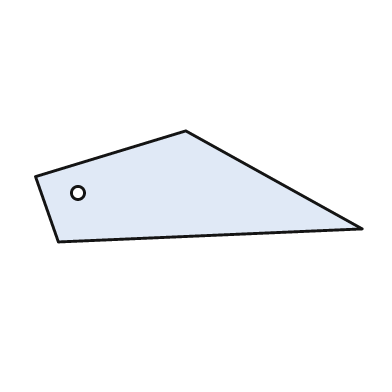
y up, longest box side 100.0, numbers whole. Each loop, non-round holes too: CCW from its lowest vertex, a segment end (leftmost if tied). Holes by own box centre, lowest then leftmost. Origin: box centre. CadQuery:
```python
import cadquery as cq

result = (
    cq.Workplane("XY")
    .moveTo(-43.0, -17.0)
    .lineTo(50.0, -13.0)
    .lineTo(-4.0, 17.0)
    .lineTo(-50.0, 3.0)
    .close()
    .moveTo(-37.0, -2.0)
    .circle(2.0)
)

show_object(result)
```